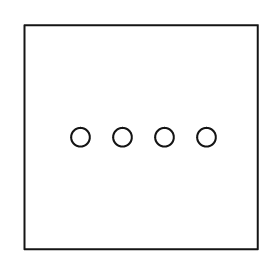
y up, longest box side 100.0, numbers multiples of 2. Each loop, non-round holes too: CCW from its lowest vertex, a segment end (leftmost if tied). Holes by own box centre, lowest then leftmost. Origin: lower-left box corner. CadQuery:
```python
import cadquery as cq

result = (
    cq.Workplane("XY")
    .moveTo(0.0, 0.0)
    .lineTo(100.0, 0.0)
    .lineTo(100.0, 96.0)
    .lineTo(0.0, 96.0)
    .close()
    .moveTo(24.0, 48.0)
    .circle(4.0)
    .moveTo(42.0, 48.0)
    .circle(4.0)
    .moveTo(60.0, 48.0)
    .circle(4.0)
    .moveTo(78.0, 48.0)
    .circle(4.0)
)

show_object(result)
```